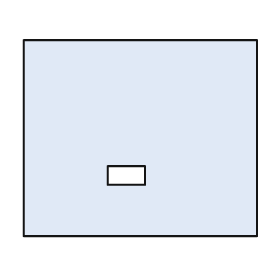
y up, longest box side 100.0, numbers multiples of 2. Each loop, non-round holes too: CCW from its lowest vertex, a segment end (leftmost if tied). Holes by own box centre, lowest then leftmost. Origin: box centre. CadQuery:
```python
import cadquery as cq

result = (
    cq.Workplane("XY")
    .moveTo(-50.0, -42.0)
    .lineTo(50.0, -42.0)
    .lineTo(50.0, 42.0)
    .lineTo(-50.0, 42.0)
    .close()
    .moveTo(-14.0, -20.0)
    .lineTo(2.0, -20.0)
    .lineTo(2.0, -12.0)
    .lineTo(-14.0, -12.0)
    .close()
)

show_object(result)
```